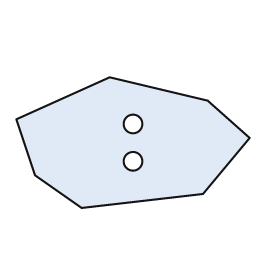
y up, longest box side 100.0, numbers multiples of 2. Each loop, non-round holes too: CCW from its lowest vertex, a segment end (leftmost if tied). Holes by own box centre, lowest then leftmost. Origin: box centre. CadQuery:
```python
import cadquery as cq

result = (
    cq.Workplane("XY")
    .moveTo(-22.0, -28.0)
    .lineTo(30.0, -22.0)
    .lineTo(50.0, 2.0)
    .lineTo(32.0, 18.0)
    .lineTo(-10.0, 28.0)
    .lineTo(-50.0, 10.0)
    .lineTo(-42.0, -14.0)
    .close()
    .moveTo(0.0, -8.0)
    .circle(4.0)
    .moveTo(0.0, 8.0)
    .circle(4.0)
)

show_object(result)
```